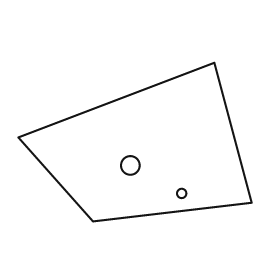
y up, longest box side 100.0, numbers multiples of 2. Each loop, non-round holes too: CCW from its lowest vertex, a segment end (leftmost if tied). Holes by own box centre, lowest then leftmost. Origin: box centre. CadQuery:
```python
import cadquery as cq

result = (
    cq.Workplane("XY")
    .moveTo(-18.0, -34.0)
    .lineTo(50.0, -26.0)
    .lineTo(34.0, 34.0)
    .lineTo(-50.0, 2.0)
    .close()
    .moveTo(20.0, -22.0)
    .circle(2.0)
    .moveTo(-2.0, -10.0)
    .circle(4.0)
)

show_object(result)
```